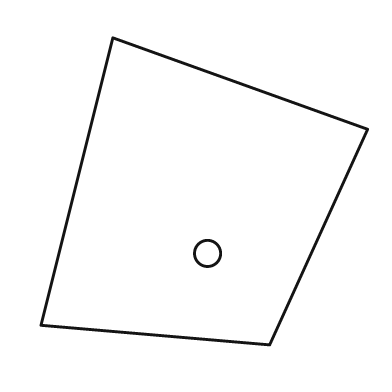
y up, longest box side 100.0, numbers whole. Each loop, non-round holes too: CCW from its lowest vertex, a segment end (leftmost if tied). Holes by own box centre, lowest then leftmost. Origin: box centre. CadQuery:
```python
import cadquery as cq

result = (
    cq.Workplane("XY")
    .moveTo(20.0, -47.0)
    .lineTo(50.0, 19.0)
    .lineTo(-28.0, 47.0)
    .lineTo(-50.0, -41.0)
    .close()
    .moveTo(1.0, -19.0)
    .circle(4.0)
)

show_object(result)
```